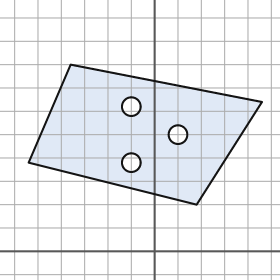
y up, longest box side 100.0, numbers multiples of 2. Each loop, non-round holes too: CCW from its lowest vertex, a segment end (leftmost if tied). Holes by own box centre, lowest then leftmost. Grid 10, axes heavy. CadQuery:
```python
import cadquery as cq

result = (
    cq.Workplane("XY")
    .moveTo(18.0, 20.0)
    .lineTo(46.0, 64.0)
    .lineTo(-36.0, 80.0)
    .lineTo(-54.0, 38.0)
    .close()
    .moveTo(-10.0, 38.0)
    .circle(4.0)
    .moveTo(10.0, 50.0)
    .circle(4.0)
    .moveTo(-10.0, 62.0)
    .circle(4.0)
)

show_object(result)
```